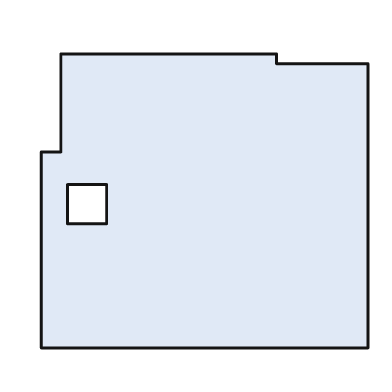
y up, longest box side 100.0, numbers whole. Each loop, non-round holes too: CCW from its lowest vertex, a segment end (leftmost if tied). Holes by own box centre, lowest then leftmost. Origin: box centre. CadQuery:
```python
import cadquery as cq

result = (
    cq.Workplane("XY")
    .moveTo(-50.0, -45.0)
    .lineTo(50.0, -45.0)
    .lineTo(50.0, 42.0)
    .lineTo(22.0, 42.0)
    .lineTo(22.0, 45.0)
    .lineTo(-44.0, 45.0)
    .lineTo(-44.0, 15.0)
    .lineTo(-50.0, 15.0)
    .close()
    .moveTo(-42.0, -7.0)
    .lineTo(-30.0, -7.0)
    .lineTo(-30.0, 5.0)
    .lineTo(-42.0, 5.0)
    .close()
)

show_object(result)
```